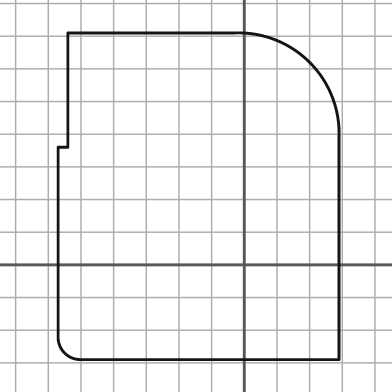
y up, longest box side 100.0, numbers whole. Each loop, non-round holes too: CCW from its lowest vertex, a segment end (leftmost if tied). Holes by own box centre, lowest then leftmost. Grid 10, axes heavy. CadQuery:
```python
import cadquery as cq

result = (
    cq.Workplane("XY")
    .moveTo(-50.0, -29.0)
    .lineTo(29.0, -29.0)
    .lineTo(29.0, 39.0)
    .threePointArc((20.0, 62.0), (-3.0, 71.0))
    .lineTo(-54.0, 71.0)
    .lineTo(-54.0, 36.0)
    .lineTo(-57.0, 36.0)
    .lineTo(-57.0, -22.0)
    .threePointArc((-55.0, -27.0), (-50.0, -29.0))
    .close()
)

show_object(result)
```